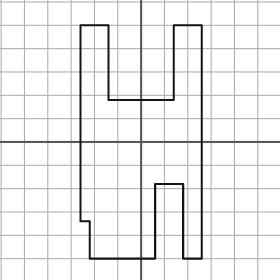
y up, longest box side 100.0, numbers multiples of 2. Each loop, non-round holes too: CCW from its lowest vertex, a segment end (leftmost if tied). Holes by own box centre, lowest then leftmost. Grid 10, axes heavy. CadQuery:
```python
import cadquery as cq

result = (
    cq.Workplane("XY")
    .moveTo(-22.0, -50.0)
    .lineTo(6.0, -50.0)
    .lineTo(6.0, -18.0)
    .lineTo(18.0, -18.0)
    .lineTo(18.0, -50.0)
    .lineTo(26.0, -50.0)
    .lineTo(26.0, 50.0)
    .lineTo(14.0, 50.0)
    .lineTo(14.0, 18.0)
    .lineTo(-14.0, 18.0)
    .lineTo(-14.0, 50.0)
    .lineTo(-26.0, 50.0)
    .lineTo(-26.0, -34.0)
    .lineTo(-22.0, -34.0)
    .close()
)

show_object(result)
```